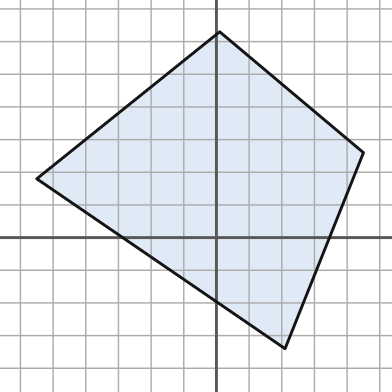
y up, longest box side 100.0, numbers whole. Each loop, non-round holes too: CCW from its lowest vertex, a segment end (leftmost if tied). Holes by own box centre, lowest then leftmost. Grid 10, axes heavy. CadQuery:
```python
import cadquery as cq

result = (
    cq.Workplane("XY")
    .moveTo(21.0, -34.0)
    .lineTo(45.0, 26.0)
    .lineTo(1.0, 63.0)
    .lineTo(-55.0, 18.0)
    .close()
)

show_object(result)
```